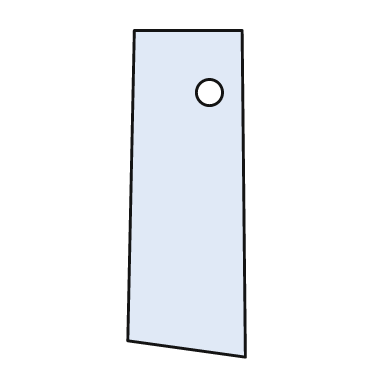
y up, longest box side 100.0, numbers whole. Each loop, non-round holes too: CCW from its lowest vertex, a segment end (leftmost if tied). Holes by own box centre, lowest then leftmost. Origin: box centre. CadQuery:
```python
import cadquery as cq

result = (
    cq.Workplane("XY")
    .moveTo(18.0, -50.0)
    .lineTo(17.0, 50.0)
    .lineTo(-16.0, 50.0)
    .lineTo(-18.0, -45.0)
    .close()
    .moveTo(7.0, 31.0)
    .circle(4.0)
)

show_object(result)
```